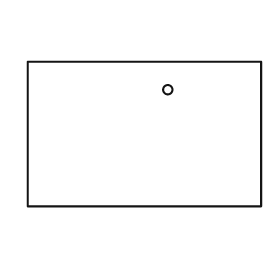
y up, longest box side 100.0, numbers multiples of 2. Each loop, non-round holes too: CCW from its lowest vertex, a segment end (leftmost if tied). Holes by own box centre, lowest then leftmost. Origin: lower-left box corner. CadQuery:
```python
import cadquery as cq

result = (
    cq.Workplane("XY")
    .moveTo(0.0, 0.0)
    .lineTo(100.0, 0.0)
    .lineTo(100.0, 62.0)
    .lineTo(0.0, 62.0)
    .close()
    .moveTo(60.0, 50.0)
    .circle(2.0)
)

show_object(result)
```